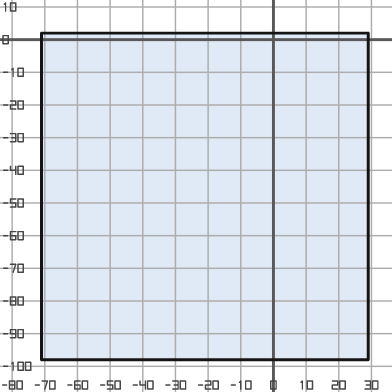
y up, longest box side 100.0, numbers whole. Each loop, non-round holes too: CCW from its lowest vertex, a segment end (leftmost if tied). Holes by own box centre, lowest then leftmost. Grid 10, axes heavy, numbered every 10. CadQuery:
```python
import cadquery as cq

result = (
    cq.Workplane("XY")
    .moveTo(-71.0, -98.0)
    .lineTo(29.0, -98.0)
    .lineTo(29.0, 2.0)
    .lineTo(-71.0, 2.0)
    .close()
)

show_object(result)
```